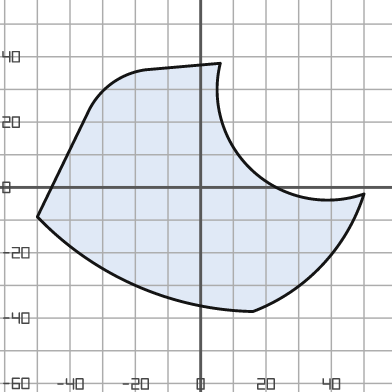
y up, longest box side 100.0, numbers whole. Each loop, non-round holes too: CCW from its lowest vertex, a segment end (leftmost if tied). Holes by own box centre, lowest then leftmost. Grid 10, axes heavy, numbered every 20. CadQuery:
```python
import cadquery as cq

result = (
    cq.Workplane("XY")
    .moveTo(16.0, -38.0)
    .threePointArc((37.0, -24.0), (50.0, -2.0))
    .threePointArc((16.0, 5.0), (6.0, 38.0))
    .lineTo(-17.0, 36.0)
    .threePointArc((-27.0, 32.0), (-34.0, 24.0))
    .lineTo(-50.0, -9.0)
    .threePointArc((-20.0, -30.0), (16.0, -38.0))
    .close()
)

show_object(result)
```